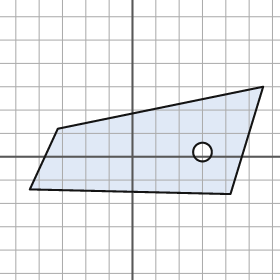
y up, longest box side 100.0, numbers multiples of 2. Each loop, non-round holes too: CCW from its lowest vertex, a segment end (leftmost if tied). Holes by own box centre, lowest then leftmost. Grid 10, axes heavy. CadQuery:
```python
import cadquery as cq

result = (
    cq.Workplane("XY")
    .moveTo(42.0, -16.0)
    .lineTo(56.0, 30.0)
    .lineTo(-32.0, 12.0)
    .lineTo(-44.0, -14.0)
    .close()
    .moveTo(30.0, 2.0)
    .circle(4.0)
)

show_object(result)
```